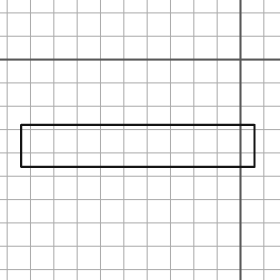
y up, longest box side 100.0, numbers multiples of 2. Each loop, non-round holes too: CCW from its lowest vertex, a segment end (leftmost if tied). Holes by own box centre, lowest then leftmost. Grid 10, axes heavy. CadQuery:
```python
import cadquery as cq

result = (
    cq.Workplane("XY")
    .moveTo(-94.0, -46.0)
    .lineTo(6.0, -46.0)
    .lineTo(6.0, -28.0)
    .lineTo(-94.0, -28.0)
    .close()
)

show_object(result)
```